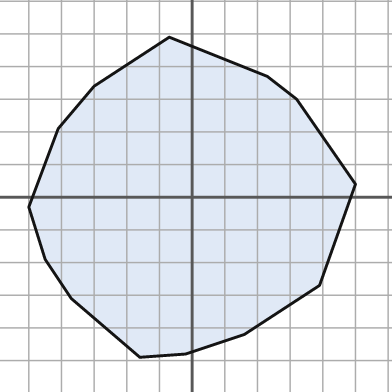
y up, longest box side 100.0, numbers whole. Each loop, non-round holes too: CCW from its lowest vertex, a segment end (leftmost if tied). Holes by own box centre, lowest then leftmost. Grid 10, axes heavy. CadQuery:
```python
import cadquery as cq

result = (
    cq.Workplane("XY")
    .moveTo(-16.0, -49.0)
    .lineTo(-2.0, -48.0)
    .lineTo(16.0, -42.0)
    .lineTo(39.0, -27.0)
    .lineTo(50.0, 4.0)
    .lineTo(32.0, 30.0)
    .lineTo(23.0, 37.0)
    .lineTo(-7.0, 49.0)
    .lineTo(-30.0, 34.0)
    .lineTo(-41.0, 21.0)
    .lineTo(-50.0, -3.0)
    .lineTo(-45.0, -19.0)
    .lineTo(-37.0, -31.0)
    .close()
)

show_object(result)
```